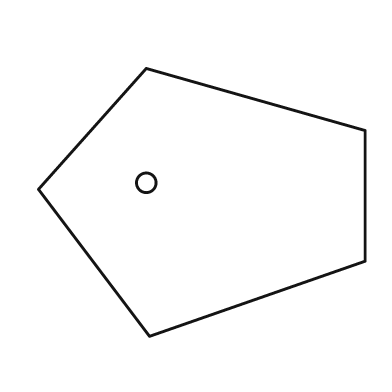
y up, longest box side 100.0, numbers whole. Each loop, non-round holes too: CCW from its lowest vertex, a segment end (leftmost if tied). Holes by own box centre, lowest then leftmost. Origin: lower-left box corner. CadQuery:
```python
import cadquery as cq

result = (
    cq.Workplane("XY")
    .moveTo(34.0, 0.0)
    .lineTo(100.0, 23.0)
    .lineTo(100.0, 63.0)
    .lineTo(33.0, 82.0)
    .lineTo(0.0, 45.0)
    .close()
    .moveTo(33.0, 47.0)
    .circle(3.0)
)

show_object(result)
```